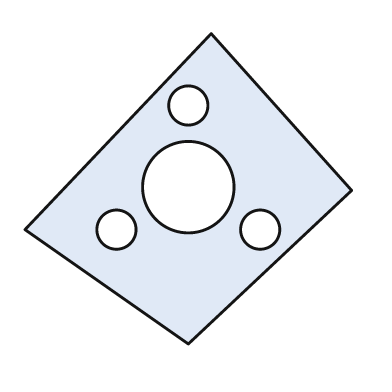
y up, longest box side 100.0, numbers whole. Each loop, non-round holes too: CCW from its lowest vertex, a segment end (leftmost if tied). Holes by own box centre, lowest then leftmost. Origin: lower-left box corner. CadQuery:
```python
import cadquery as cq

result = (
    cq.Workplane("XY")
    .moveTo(50.0, 0.0)
    .lineTo(100.0, 47.0)
    .lineTo(57.0, 95.0)
    .lineTo(0.0, 35.0)
    .close()
    .moveTo(28.0, 35.0)
    .circle(6.0)
    .moveTo(72.0, 35.0)
    .circle(6.0)
    .moveTo(50.0, 48.0)
    .circle(14.0)
    .moveTo(50.0, 73.0)
    .circle(6.0)
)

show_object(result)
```